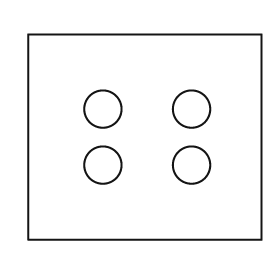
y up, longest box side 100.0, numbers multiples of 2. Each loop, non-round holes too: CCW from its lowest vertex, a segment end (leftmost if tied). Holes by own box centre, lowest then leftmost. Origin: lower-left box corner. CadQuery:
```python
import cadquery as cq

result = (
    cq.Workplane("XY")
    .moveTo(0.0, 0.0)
    .lineTo(100.0, 0.0)
    .lineTo(100.0, 88.0)
    .lineTo(0.0, 88.0)
    .close()
    .moveTo(32.0, 32.0)
    .circle(8.0)
    .moveTo(70.0, 32.0)
    .circle(8.0)
    .moveTo(32.0, 56.0)
    .circle(8.0)
    .moveTo(70.0, 56.0)
    .circle(8.0)
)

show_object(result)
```